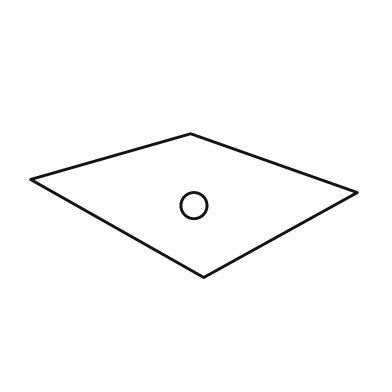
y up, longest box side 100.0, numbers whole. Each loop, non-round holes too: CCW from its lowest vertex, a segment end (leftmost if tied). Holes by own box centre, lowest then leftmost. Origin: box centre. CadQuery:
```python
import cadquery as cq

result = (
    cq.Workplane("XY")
    .moveTo(3.0, -22.0)
    .lineTo(50.0, 4.0)
    .lineTo(-1.0, 22.0)
    .lineTo(-50.0, 8.0)
    .close()
    .moveTo(0.0, 0.0)
    .circle(4.0)
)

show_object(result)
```